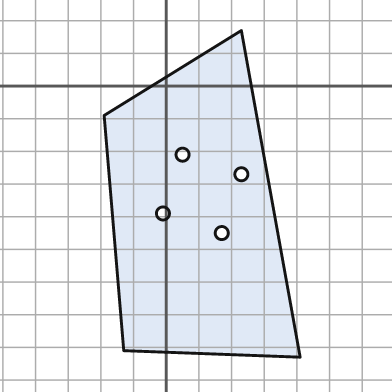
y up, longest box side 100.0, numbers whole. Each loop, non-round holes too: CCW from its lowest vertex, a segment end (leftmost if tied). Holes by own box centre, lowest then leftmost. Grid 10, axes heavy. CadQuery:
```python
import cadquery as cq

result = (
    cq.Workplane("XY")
    .moveTo(41.0, -83.0)
    .lineTo(23.0, 17.0)
    .lineTo(-19.0, -9.0)
    .lineTo(-13.0, -81.0)
    .close()
    .moveTo(17.0, -45.0)
    .circle(2.0)
    .moveTo(-1.0, -39.0)
    .circle(2.0)
    .moveTo(23.0, -27.0)
    .circle(2.0)
    .moveTo(5.0, -21.0)
    .circle(2.0)
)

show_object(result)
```